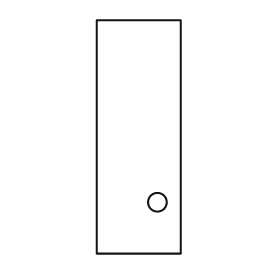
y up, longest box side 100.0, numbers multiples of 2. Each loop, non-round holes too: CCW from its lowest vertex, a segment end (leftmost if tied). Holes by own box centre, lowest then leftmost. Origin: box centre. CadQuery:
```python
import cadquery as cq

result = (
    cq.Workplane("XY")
    .moveTo(-18.0, -50.0)
    .lineTo(18.0, -50.0)
    .lineTo(18.0, 50.0)
    .lineTo(-18.0, 50.0)
    .close()
    .moveTo(8.0, -28.0)
    .circle(4.0)
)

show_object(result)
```